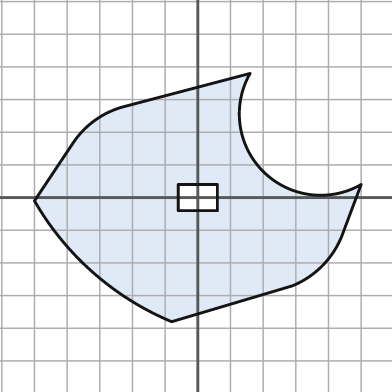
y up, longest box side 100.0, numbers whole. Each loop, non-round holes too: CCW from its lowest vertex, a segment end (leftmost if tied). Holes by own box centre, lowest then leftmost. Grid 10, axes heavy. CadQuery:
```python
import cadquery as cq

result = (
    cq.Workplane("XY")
    .moveTo(-8.0, -38.0)
    .lineTo(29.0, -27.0)
    .threePointArc((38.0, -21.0), (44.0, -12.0))
    .lineTo(50.0, 4.0)
    .threePointArc((20.0, 8.0), (16.0, 38.0))
    .lineTo(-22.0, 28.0)
    .threePointArc((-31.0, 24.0), (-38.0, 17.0))
    .lineTo(-50.0, -1.0)
    .threePointArc((-32.0, -23.0), (-8.0, -38.0))
    .close()
    .moveTo(-6.0, -4.0)
    .lineTo(6.0, -4.0)
    .lineTo(6.0, 4.0)
    .lineTo(-6.0, 4.0)
    .close()
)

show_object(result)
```